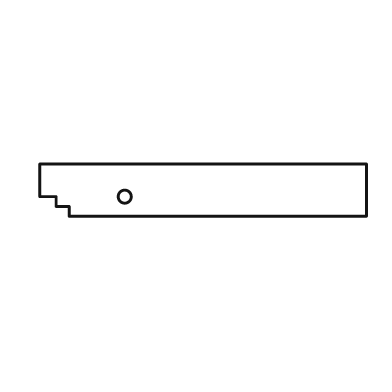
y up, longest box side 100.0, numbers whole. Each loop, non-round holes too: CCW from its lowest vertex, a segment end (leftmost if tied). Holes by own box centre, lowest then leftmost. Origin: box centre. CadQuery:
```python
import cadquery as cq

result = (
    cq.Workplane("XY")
    .moveTo(-41.0, -8.0)
    .lineTo(50.0, -8.0)
    .lineTo(50.0, 8.0)
    .lineTo(-50.0, 8.0)
    .lineTo(-50.0, -2.0)
    .lineTo(-45.0, -2.0)
    .lineTo(-45.0, -5.0)
    .lineTo(-41.0, -5.0)
    .close()
    .moveTo(-24.0, -2.0)
    .circle(2.0)
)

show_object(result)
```